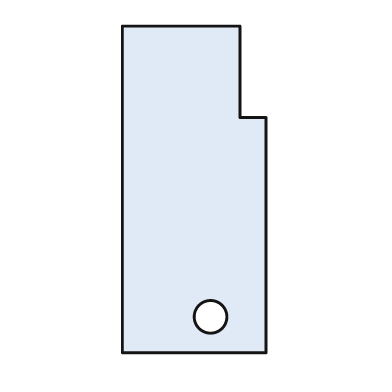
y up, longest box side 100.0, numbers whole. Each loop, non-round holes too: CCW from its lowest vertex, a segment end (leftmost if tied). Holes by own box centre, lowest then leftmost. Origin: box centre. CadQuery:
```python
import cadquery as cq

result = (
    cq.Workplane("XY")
    .moveTo(-22.0, -50.0)
    .lineTo(22.0, -50.0)
    .lineTo(22.0, 22.0)
    .lineTo(14.0, 22.0)
    .lineTo(14.0, 50.0)
    .lineTo(-22.0, 50.0)
    .close()
    .moveTo(5.0, -39.0)
    .circle(5.0)
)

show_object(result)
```